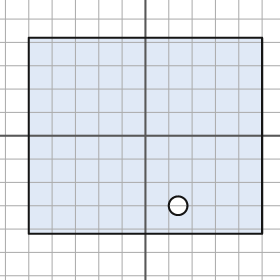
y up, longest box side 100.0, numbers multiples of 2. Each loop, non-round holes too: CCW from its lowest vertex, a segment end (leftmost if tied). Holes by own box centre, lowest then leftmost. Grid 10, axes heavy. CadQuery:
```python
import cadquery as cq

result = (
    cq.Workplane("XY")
    .moveTo(-50.0, -42.0)
    .lineTo(50.0, -42.0)
    .lineTo(50.0, 42.0)
    .lineTo(-50.0, 42.0)
    .close()
    .moveTo(14.0, -30.0)
    .circle(4.0)
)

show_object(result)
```